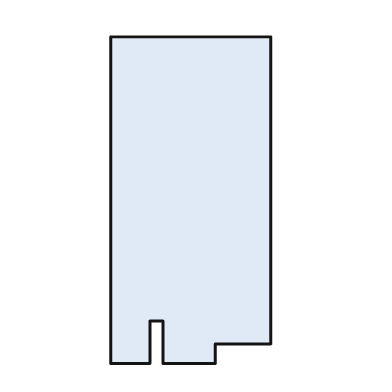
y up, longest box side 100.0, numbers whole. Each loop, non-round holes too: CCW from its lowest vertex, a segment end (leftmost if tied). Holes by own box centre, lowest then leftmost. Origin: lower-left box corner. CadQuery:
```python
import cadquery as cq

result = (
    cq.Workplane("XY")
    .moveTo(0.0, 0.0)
    .lineTo(12.0, 0.0)
    .lineTo(12.0, 13.0)
    .lineTo(16.0, 13.0)
    .lineTo(16.0, 0.0)
    .lineTo(32.0, 0.0)
    .lineTo(32.0, 6.0)
    .lineTo(49.0, 6.0)
    .lineTo(49.0, 100.0)
    .lineTo(0.0, 100.0)
    .close()
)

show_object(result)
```